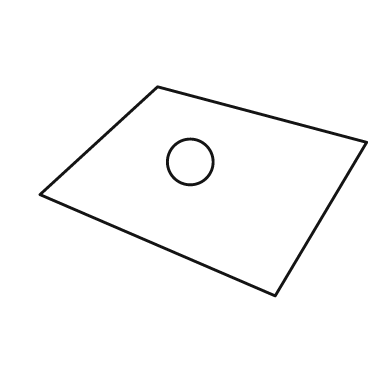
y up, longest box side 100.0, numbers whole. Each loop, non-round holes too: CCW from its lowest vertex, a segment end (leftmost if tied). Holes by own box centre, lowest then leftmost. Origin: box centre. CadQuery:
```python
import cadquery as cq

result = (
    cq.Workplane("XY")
    .moveTo(22.0, -32.0)
    .lineTo(50.0, 15.0)
    .lineTo(-14.0, 32.0)
    .lineTo(-50.0, -1.0)
    .close()
    .moveTo(-4.0, 9.0)
    .circle(7.0)
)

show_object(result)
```